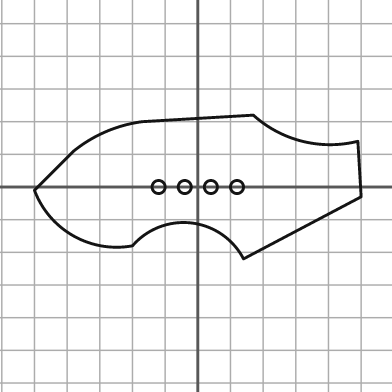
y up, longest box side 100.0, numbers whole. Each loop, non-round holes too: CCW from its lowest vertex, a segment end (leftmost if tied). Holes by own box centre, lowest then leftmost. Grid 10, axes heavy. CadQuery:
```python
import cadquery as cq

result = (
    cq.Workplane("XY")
    .moveTo(14.0, -22.0)
    .lineTo(50.0, -3.0)
    .lineTo(49.0, 14.0)
    .threePointArc((32.0, 14.0), (17.0, 22.0))
    .lineTo(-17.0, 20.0)
    .threePointArc((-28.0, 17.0), (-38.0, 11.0))
    .lineTo(-50.0, -1.0)
    .threePointArc((-38.0, -15.0), (-20.0, -18.0))
    .threePointArc((-2.0, -11.0), (14.0, -22.0))
    .close()
    .moveTo(-12.0, 0.0)
    .circle(2.0)
    .moveTo(-4.0, 0.0)
    .circle(2.0)
    .moveTo(4.0, 0.0)
    .circle(2.0)
    .moveTo(12.0, 0.0)
    .circle(2.0)
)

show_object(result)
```